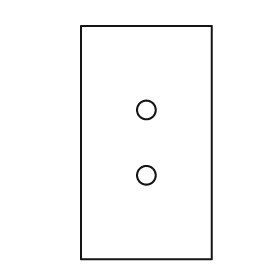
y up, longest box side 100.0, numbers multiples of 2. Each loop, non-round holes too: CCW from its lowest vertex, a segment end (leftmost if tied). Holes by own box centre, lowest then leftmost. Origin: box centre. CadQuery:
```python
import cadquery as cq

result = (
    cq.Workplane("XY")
    .moveTo(-28.0, -50.0)
    .lineTo(28.0, -50.0)
    .lineTo(28.0, 50.0)
    .lineTo(-28.0, 50.0)
    .close()
    .moveTo(0.0, -14.0)
    .circle(4.0)
    .moveTo(0.0, 14.0)
    .circle(4.0)
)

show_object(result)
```